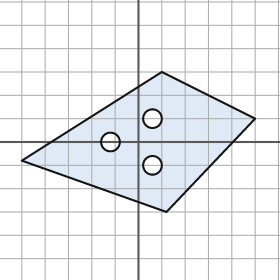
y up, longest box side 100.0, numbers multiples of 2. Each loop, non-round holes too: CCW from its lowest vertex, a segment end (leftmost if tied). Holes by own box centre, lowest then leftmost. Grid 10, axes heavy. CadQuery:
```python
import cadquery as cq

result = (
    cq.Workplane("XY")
    .moveTo(12.0, -30.0)
    .lineTo(50.0, 10.0)
    .lineTo(10.0, 30.0)
    .lineTo(-50.0, -8.0)
    .close()
    .moveTo(6.0, -10.0)
    .circle(4.0)
    .moveTo(-12.0, 0.0)
    .circle(4.0)
    .moveTo(6.0, 10.0)
    .circle(4.0)
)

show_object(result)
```